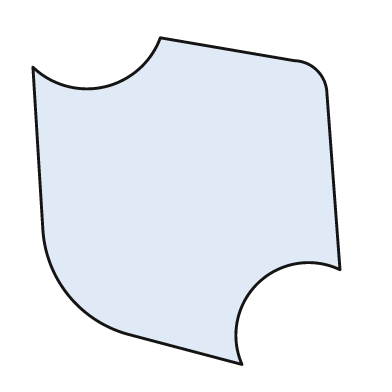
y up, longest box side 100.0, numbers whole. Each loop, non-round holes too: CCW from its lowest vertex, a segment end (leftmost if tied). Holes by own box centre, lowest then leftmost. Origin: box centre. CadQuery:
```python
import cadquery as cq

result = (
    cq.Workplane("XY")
    .moveTo(17.0, -50.0)
    .threePointArc((22.0, -25.0), (47.0, -21.0))
    .lineTo(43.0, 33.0)
    .threePointArc((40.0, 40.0), (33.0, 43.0))
    .lineTo(-8.0, 50.0)
    .threePointArc((-25.0, 35.0), (-47.0, 41.0))
    .lineTo(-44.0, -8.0)
    .threePointArc((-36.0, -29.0), (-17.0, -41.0))
    .close()
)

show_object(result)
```